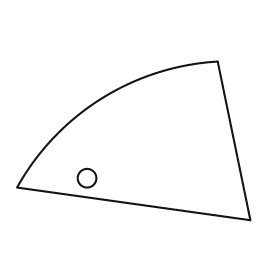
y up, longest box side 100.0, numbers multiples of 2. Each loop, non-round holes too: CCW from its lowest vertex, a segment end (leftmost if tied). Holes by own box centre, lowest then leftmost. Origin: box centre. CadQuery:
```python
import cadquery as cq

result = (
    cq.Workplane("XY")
    .moveTo(50.0, -34.0)
    .lineTo(36.0, 34.0)
    .threePointArc((-14.0, 18.0), (-50.0, -20.0))
    .close()
    .moveTo(-20.0, -16.0)
    .circle(4.0)
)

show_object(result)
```